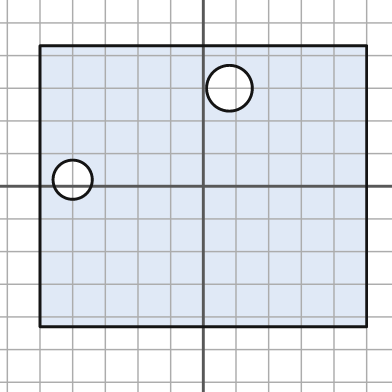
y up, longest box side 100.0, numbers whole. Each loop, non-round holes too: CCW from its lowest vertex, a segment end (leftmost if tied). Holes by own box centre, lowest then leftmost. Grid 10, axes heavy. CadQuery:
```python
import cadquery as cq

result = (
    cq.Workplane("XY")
    .moveTo(-50.0, -43.0)
    .lineTo(50.0, -43.0)
    .lineTo(50.0, 43.0)
    .lineTo(-50.0, 43.0)
    .close()
    .moveTo(-40.0, 2.0)
    .circle(6.0)
    .moveTo(8.0, 30.0)
    .circle(7.0)
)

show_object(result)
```